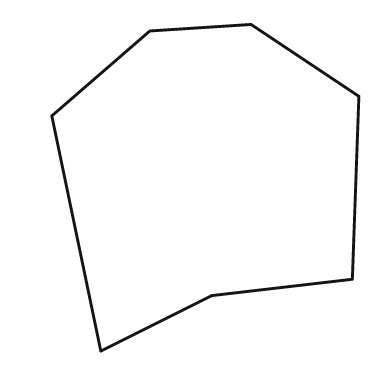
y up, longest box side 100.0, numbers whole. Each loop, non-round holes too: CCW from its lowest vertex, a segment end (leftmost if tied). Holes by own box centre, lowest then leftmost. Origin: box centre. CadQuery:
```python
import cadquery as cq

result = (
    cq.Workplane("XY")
    .moveTo(-32.0, -50.0)
    .lineTo(2.0, -33.0)
    .lineTo(45.0, -28.0)
    .lineTo(47.0, 28.0)
    .lineTo(14.0, 50.0)
    .lineTo(-17.0, 48.0)
    .lineTo(-47.0, 22.0)
    .close()
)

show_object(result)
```